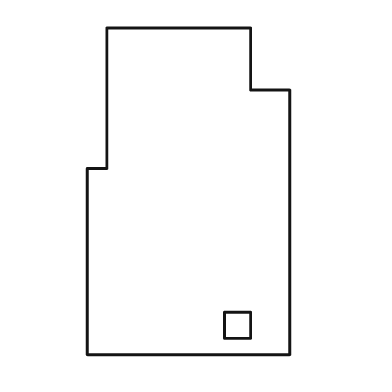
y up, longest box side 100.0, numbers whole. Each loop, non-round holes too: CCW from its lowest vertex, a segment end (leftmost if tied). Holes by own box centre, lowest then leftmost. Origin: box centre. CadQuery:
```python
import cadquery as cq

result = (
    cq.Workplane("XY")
    .moveTo(-31.0, -50.0)
    .lineTo(31.0, -50.0)
    .lineTo(31.0, 31.0)
    .lineTo(19.0, 31.0)
    .lineTo(19.0, 50.0)
    .lineTo(-25.0, 50.0)
    .lineTo(-25.0, 7.0)
    .lineTo(-31.0, 7.0)
    .close()
    .moveTo(11.0, -45.0)
    .lineTo(19.0, -45.0)
    .lineTo(19.0, -37.0)
    .lineTo(11.0, -37.0)
    .close()
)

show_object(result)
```